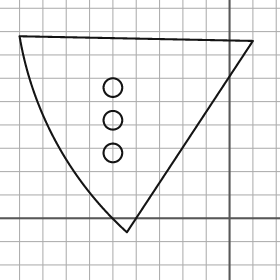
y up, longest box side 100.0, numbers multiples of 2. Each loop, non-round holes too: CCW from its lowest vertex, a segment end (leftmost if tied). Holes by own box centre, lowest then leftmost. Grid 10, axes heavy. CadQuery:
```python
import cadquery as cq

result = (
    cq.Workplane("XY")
    .moveTo(-44.0, -6.0)
    .lineTo(10.0, 76.0)
    .lineTo(-90.0, 78.0)
    .threePointArc((-74.0, 32.0), (-44.0, -6.0))
    .close()
    .moveTo(-50.0, 28.0)
    .circle(4.0)
    .moveTo(-50.0, 42.0)
    .circle(4.0)
    .moveTo(-50.0, 56.0)
    .circle(4.0)
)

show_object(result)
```